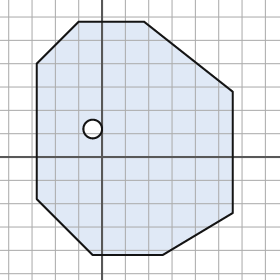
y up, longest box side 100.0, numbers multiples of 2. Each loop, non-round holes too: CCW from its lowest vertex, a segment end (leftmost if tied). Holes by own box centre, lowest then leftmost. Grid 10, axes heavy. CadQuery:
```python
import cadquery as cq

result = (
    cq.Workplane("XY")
    .moveTo(-4.0, -42.0)
    .lineTo(26.0, -42.0)
    .lineTo(56.0, -24.0)
    .lineTo(56.0, 28.0)
    .lineTo(18.0, 58.0)
    .lineTo(-10.0, 58.0)
    .lineTo(-28.0, 40.0)
    .lineTo(-28.0, -18.0)
    .close()
    .moveTo(-4.0, 12.0)
    .circle(4.0)
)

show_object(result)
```